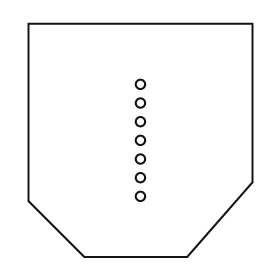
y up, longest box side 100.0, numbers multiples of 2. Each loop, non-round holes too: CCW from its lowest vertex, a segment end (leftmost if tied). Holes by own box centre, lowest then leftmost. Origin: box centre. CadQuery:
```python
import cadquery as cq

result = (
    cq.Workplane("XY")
    .moveTo(-24.0, -50.0)
    .lineTo(20.0, -50.0)
    .lineTo(48.0, -18.0)
    .lineTo(48.0, 50.0)
    .lineTo(-48.0, 50.0)
    .lineTo(-48.0, -26.0)
    .close()
    .moveTo(0.0, -24.0)
    .circle(2.0)
    .moveTo(0.0, -16.0)
    .circle(2.0)
    .moveTo(0.0, -8.0)
    .circle(2.0)
    .moveTo(0.0, 0.0)
    .circle(2.0)
    .moveTo(0.0, 8.0)
    .circle(2.0)
    .moveTo(0.0, 16.0)
    .circle(2.0)
    .moveTo(0.0, 24.0)
    .circle(2.0)
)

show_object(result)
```